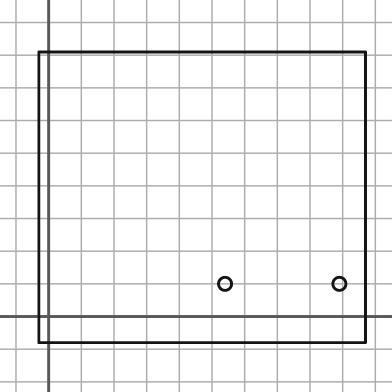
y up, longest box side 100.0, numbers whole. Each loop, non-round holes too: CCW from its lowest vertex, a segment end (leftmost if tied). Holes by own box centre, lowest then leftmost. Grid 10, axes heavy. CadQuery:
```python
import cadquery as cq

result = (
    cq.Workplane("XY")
    .moveTo(-3.0, -8.0)
    .lineTo(97.0, -8.0)
    .lineTo(97.0, 81.0)
    .lineTo(-3.0, 81.0)
    .close()
    .moveTo(54.0, 10.0)
    .circle(2.0)
    .moveTo(89.0, 10.0)
    .circle(2.0)
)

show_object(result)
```